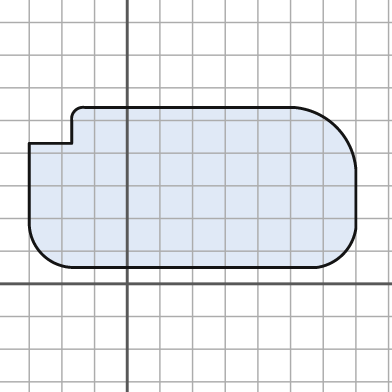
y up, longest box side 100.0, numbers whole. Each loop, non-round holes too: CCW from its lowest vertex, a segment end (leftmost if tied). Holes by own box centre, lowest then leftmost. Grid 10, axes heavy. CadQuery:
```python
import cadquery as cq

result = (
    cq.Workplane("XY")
    .moveTo(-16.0, 5.0)
    .lineTo(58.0, 5.0)
    .threePointArc((66.0, 9.0), (70.0, 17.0))
    .lineTo(70.0, 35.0)
    .threePointArc((64.0, 48.0), (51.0, 54.0))
    .lineTo(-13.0, 54.0)
    .threePointArc((-16.0, 53.0), (-17.0, 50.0))
    .lineTo(-17.0, 43.0)
    .lineTo(-30.0, 43.0)
    .lineTo(-30.0, 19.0)
    .threePointArc((-26.0, 9.0), (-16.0, 5.0))
    .close()
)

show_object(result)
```